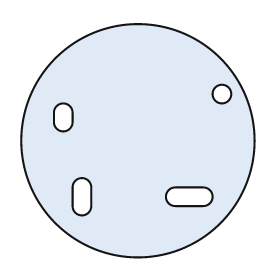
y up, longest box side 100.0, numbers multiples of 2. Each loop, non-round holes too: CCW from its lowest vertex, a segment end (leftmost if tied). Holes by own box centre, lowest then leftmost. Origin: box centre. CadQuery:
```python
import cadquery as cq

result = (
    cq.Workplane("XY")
    .moveTo(0.0, 0.0)
    .circle(50.0)
    .moveTo(-28.0, -28.0)
    .threePointArc((-24.0, -32.0), (-20.0, -28.0))
    .lineTo(-20.0, -20.0)
    .threePointArc((-24.0, -16.0), (-28.0, -20.0))
    .close()
    .moveTo(16.0, -28.0)
    .lineTo(28.0, -28.0)
    .threePointArc((32.0, -24.0), (28.0, -20.0))
    .lineTo(16.0, -20.0)
    .threePointArc((12.0, -24.0), (16.0, -28.0))
    .close()
    .moveTo(-36.0, 8.0)
    .threePointArc((-32.0, 4.0), (-28.0, 8.0))
    .lineTo(-28.0, 12.0)
    .threePointArc((-32.0, 16.0), (-36.0, 12.0))
    .close()
    .moveTo(36.0, 20.0)
    .circle(4.0)
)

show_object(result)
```